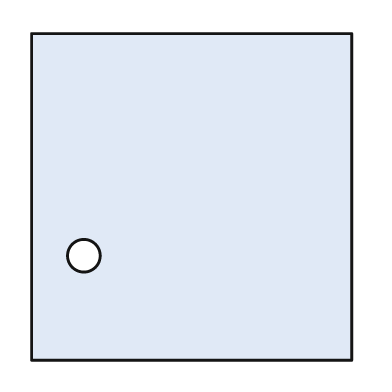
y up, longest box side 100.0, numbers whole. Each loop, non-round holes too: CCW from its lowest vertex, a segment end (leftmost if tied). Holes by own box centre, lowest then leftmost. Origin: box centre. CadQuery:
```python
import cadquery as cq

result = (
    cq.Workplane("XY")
    .moveTo(-49.0, -50.0)
    .lineTo(49.0, -50.0)
    .lineTo(49.0, 50.0)
    .lineTo(-49.0, 50.0)
    .close()
    .moveTo(-33.0, -18.0)
    .circle(5.0)
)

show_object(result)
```